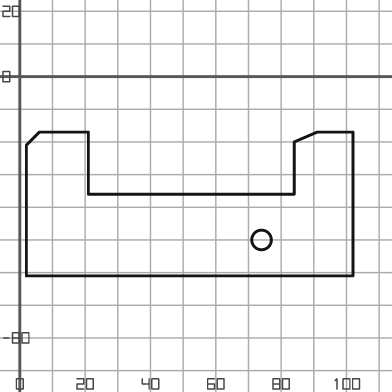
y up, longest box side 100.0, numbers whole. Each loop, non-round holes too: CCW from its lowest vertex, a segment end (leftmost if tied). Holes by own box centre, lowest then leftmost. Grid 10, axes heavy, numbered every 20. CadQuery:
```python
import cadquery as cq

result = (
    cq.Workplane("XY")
    .moveTo(2.0, -61.0)
    .lineTo(102.0, -61.0)
    .lineTo(102.0, -17.0)
    .lineTo(91.0, -17.0)
    .lineTo(84.0, -20.0)
    .lineTo(84.0, -36.0)
    .lineTo(21.0, -36.0)
    .lineTo(21.0, -17.0)
    .lineTo(6.0, -17.0)
    .lineTo(2.0, -21.0)
    .close()
    .moveTo(74.0, -50.0)
    .circle(3.0)
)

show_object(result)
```